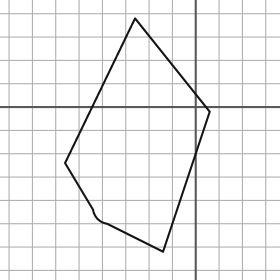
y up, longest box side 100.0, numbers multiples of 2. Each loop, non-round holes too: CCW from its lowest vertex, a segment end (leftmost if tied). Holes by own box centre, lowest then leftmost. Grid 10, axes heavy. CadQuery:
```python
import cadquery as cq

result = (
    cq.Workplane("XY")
    .moveTo(-14.0, -62.0)
    .lineTo(6.0, -2.0)
    .lineTo(-26.0, 38.0)
    .lineTo(-56.0, -24.0)
    .lineTo(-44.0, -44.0)
    .threePointArc((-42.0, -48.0), (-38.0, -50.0))
    .close()
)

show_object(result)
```